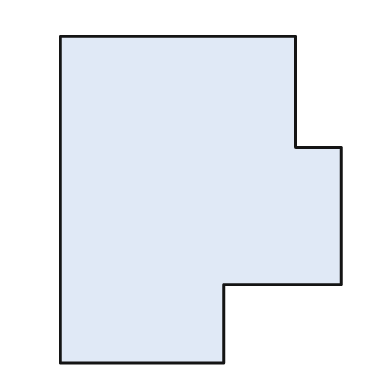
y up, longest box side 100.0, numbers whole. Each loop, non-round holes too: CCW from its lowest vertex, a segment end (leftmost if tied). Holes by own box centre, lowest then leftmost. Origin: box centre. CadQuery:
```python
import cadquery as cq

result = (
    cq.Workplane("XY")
    .moveTo(-43.0, -50.0)
    .lineTo(7.0, -50.0)
    .lineTo(7.0, -26.0)
    .lineTo(43.0, -26.0)
    .lineTo(43.0, 16.0)
    .lineTo(29.0, 16.0)
    .lineTo(29.0, 50.0)
    .lineTo(-43.0, 50.0)
    .close()
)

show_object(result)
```